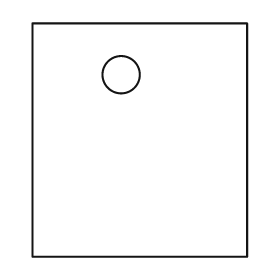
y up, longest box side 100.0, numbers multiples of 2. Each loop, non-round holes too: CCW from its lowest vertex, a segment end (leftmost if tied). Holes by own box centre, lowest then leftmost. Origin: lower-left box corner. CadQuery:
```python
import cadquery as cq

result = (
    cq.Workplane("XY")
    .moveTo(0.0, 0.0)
    .lineTo(92.0, 0.0)
    .lineTo(92.0, 100.0)
    .lineTo(0.0, 100.0)
    .close()
    .moveTo(38.0, 78.0)
    .circle(8.0)
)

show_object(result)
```